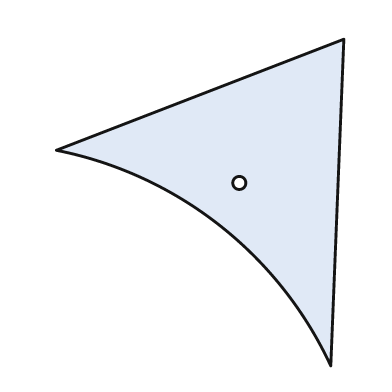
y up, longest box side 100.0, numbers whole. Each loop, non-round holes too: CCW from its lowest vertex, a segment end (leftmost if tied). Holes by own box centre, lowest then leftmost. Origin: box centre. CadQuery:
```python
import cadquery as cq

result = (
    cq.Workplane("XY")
    .moveTo(40.0, -50.0)
    .lineTo(44.0, 50.0)
    .lineTo(-44.0, 16.0)
    .threePointArc((6.0, -7.0), (40.0, -50.0))
    .close()
    .moveTo(12.0, 6.0)
    .circle(2.0)
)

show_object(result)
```